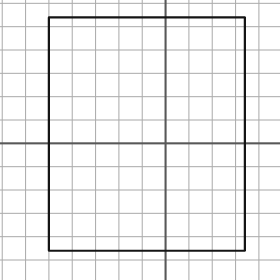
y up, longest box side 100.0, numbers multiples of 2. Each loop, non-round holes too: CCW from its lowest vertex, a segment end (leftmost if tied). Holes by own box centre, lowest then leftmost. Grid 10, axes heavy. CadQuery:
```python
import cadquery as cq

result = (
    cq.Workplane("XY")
    .moveTo(-50.0, -46.0)
    .lineTo(34.0, -46.0)
    .lineTo(34.0, 54.0)
    .lineTo(-50.0, 54.0)
    .close()
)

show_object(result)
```